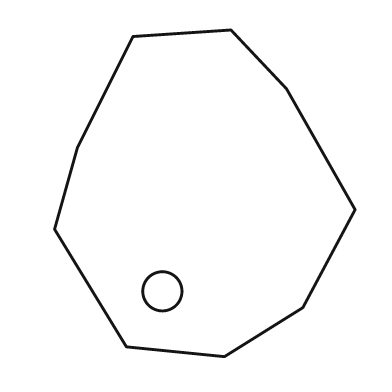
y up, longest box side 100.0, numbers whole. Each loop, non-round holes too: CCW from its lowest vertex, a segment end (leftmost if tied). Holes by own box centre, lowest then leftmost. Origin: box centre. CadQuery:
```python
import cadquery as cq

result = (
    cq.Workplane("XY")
    .moveTo(6.0, -50.0)
    .lineTo(30.0, -35.0)
    .lineTo(46.0, -5.0)
    .lineTo(25.0, 32.0)
    .lineTo(8.0, 50.0)
    .lineTo(-22.0, 48.0)
    .lineTo(-39.0, 14.0)
    .lineTo(-46.0, -11.0)
    .lineTo(-24.0, -47.0)
    .close()
    .moveTo(-13.0, -30.0)
    .circle(6.0)
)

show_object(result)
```